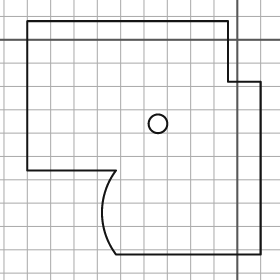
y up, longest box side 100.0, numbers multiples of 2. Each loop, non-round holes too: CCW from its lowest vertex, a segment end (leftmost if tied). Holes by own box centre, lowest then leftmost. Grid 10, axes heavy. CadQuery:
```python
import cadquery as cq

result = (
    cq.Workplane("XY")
    .moveTo(-52.0, -92.0)
    .lineTo(10.0, -92.0)
    .lineTo(10.0, -18.0)
    .lineTo(-4.0, -18.0)
    .lineTo(-4.0, 8.0)
    .lineTo(-90.0, 8.0)
    .lineTo(-90.0, -56.0)
    .lineTo(-52.0, -56.0)
    .threePointArc((-58.0, -74.0), (-52.0, -92.0))
    .close()
    .moveTo(-34.0, -36.0)
    .circle(4.0)
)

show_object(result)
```